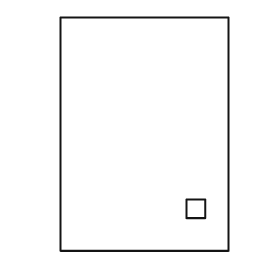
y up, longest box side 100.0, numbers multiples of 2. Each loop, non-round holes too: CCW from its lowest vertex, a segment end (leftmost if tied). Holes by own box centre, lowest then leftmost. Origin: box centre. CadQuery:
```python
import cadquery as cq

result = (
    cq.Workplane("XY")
    .moveTo(-36.0, -50.0)
    .lineTo(36.0, -50.0)
    .lineTo(36.0, 50.0)
    .lineTo(-36.0, 50.0)
    .close()
    .moveTo(18.0, -36.0)
    .lineTo(26.0, -36.0)
    .lineTo(26.0, -28.0)
    .lineTo(18.0, -28.0)
    .close()
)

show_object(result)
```